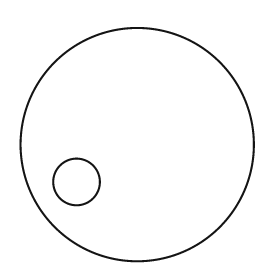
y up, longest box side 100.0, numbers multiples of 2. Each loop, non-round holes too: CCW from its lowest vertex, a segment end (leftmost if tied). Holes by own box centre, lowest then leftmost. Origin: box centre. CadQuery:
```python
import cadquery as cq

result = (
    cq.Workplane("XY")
    .moveTo(0.0, 0.0)
    .circle(50.0)
    .moveTo(-26.0, -16.0)
    .circle(10.0)
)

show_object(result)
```